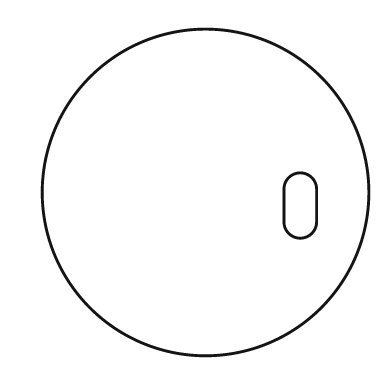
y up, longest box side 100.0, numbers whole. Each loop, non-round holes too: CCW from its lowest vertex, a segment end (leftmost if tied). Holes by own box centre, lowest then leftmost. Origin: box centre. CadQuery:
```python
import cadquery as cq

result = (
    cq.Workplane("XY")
    .moveTo(0.0, 0.0)
    .circle(50.0)
    .moveTo(24.0, -9.0)
    .threePointArc((29.0, -14.0), (34.0, -9.0))
    .lineTo(34.0, 1.0)
    .threePointArc((29.0, 6.0), (24.0, 1.0))
    .close()
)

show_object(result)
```